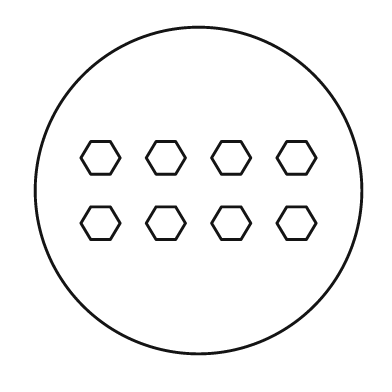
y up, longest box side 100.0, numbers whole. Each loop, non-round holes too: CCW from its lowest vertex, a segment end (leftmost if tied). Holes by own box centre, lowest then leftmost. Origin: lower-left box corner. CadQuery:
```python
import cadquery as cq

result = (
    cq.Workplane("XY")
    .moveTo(50.0, 50.0)
    .circle(50.0)
    .moveTo(17.0, 35.0)
    .lineTo(23.0, 35.0)
    .lineTo(26.0, 40.0)
    .lineTo(23.0, 45.0)
    .lineTo(17.0, 45.0)
    .lineTo(14.0, 40.0)
    .close()
    .moveTo(37.0, 35.0)
    .lineTo(43.0, 35.0)
    .lineTo(46.0, 40.0)
    .lineTo(43.0, 45.0)
    .lineTo(37.0, 45.0)
    .lineTo(34.0, 40.0)
    .close()
    .moveTo(57.0, 35.0)
    .lineTo(63.0, 35.0)
    .lineTo(66.0, 40.0)
    .lineTo(63.0, 45.0)
    .lineTo(57.0, 45.0)
    .lineTo(54.0, 40.0)
    .close()
    .moveTo(77.0, 35.0)
    .lineTo(83.0, 35.0)
    .lineTo(86.0, 40.0)
    .lineTo(83.0, 45.0)
    .lineTo(77.0, 45.0)
    .lineTo(74.0, 40.0)
    .close()
    .moveTo(17.0, 55.0)
    .lineTo(23.0, 55.0)
    .lineTo(26.0, 60.0)
    .lineTo(23.0, 65.0)
    .lineTo(17.0, 65.0)
    .lineTo(14.0, 60.0)
    .close()
    .moveTo(37.0, 55.0)
    .lineTo(43.0, 55.0)
    .lineTo(46.0, 60.0)
    .lineTo(43.0, 65.0)
    .lineTo(37.0, 65.0)
    .lineTo(34.0, 60.0)
    .close()
    .moveTo(57.0, 55.0)
    .lineTo(63.0, 55.0)
    .lineTo(66.0, 60.0)
    .lineTo(63.0, 65.0)
    .lineTo(57.0, 65.0)
    .lineTo(54.0, 60.0)
    .close()
    .moveTo(77.0, 55.0)
    .lineTo(83.0, 55.0)
    .lineTo(86.0, 60.0)
    .lineTo(83.0, 65.0)
    .lineTo(77.0, 65.0)
    .lineTo(74.0, 60.0)
    .close()
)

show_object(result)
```